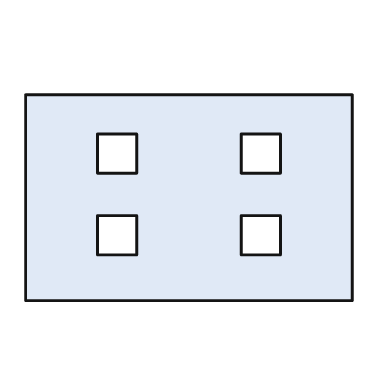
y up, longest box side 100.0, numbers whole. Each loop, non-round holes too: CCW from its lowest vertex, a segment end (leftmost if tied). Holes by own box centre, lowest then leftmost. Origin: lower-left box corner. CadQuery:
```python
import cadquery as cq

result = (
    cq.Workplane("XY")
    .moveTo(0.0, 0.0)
    .lineTo(100.0, 0.0)
    .lineTo(100.0, 63.0)
    .lineTo(0.0, 63.0)
    .close()
    .moveTo(22.0, 14.0)
    .lineTo(34.0, 14.0)
    .lineTo(34.0, 26.0)
    .lineTo(22.0, 26.0)
    .close()
    .moveTo(66.0, 14.0)
    .lineTo(78.0, 14.0)
    .lineTo(78.0, 26.0)
    .lineTo(66.0, 26.0)
    .close()
    .moveTo(22.0, 39.0)
    .lineTo(34.0, 39.0)
    .lineTo(34.0, 51.0)
    .lineTo(22.0, 51.0)
    .close()
    .moveTo(66.0, 39.0)
    .lineTo(78.0, 39.0)
    .lineTo(78.0, 51.0)
    .lineTo(66.0, 51.0)
    .close()
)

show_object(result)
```